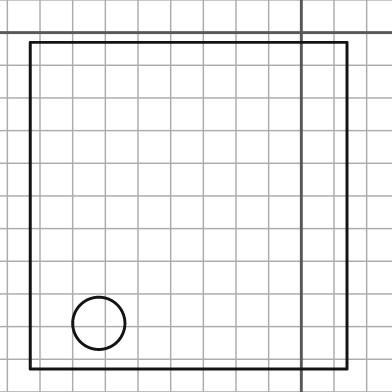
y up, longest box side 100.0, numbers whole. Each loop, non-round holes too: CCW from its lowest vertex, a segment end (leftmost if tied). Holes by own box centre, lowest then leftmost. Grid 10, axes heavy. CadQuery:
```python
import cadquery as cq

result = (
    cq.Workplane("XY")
    .moveTo(-83.0, -103.0)
    .lineTo(14.0, -103.0)
    .lineTo(14.0, -3.0)
    .lineTo(-83.0, -3.0)
    .close()
    .moveTo(-62.0, -89.0)
    .circle(8.0)
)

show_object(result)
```